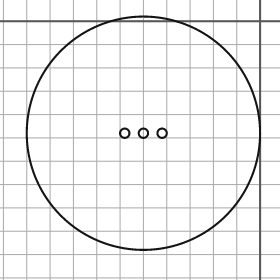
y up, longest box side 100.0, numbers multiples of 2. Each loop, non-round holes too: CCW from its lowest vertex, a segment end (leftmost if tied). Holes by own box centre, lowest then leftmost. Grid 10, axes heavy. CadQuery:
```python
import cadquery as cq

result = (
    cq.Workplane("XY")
    .moveTo(-50.0, -48.0)
    .circle(50.0)
    .moveTo(-58.0, -48.0)
    .circle(2.0)
    .moveTo(-50.0, -48.0)
    .circle(2.0)
    .moveTo(-42.0, -48.0)
    .circle(2.0)
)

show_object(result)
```